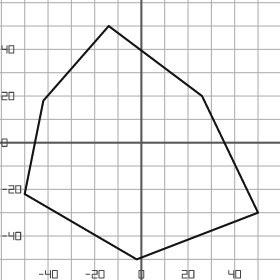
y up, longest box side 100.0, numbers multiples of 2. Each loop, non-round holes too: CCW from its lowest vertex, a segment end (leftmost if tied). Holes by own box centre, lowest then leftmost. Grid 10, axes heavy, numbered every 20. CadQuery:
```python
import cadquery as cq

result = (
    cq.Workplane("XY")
    .moveTo(-2.0, -50.0)
    .lineTo(50.0, -30.0)
    .lineTo(26.0, 20.0)
    .lineTo(-14.0, 50.0)
    .lineTo(-42.0, 18.0)
    .lineTo(-50.0, -22.0)
    .close()
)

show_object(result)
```